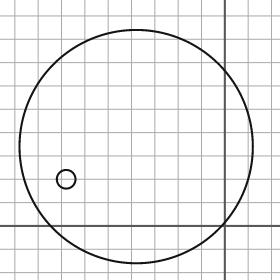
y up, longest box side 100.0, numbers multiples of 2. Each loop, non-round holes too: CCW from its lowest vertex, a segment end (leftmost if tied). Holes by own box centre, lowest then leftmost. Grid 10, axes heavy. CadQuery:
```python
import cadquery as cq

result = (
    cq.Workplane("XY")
    .moveTo(-38.0, 34.0)
    .circle(50.0)
    .moveTo(-68.0, 20.0)
    .circle(4.0)
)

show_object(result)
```